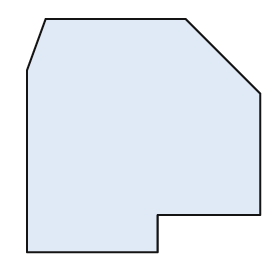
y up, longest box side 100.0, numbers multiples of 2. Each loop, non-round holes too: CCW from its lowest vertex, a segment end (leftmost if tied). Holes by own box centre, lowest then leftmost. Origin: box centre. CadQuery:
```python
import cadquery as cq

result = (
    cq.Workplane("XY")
    .moveTo(-50.0, -50.0)
    .lineTo(6.0, -50.0)
    .lineTo(6.0, -34.0)
    .lineTo(50.0, -34.0)
    .lineTo(50.0, 18.0)
    .lineTo(18.0, 50.0)
    .lineTo(-42.0, 50.0)
    .lineTo(-50.0, 28.0)
    .close()
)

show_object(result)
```